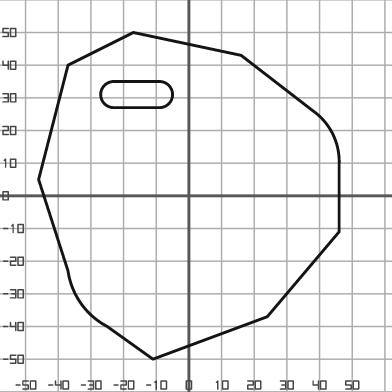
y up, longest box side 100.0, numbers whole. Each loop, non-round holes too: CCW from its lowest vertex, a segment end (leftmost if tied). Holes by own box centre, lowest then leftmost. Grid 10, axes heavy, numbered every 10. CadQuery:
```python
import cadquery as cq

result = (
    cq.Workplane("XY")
    .moveTo(-11.0, -50.0)
    .lineTo(24.0, -37.0)
    .lineTo(46.0, -11.0)
    .lineTo(46.0, 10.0)
    .threePointArc((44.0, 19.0), (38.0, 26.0))
    .lineTo(16.0, 43.0)
    .lineTo(-17.0, 50.0)
    .lineTo(-37.0, 40.0)
    .lineTo(-46.0, 5.0)
    .lineTo(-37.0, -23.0)
    .threePointArc((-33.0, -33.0), (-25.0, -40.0))
    .close()
    .moveTo(-23.0, 27.0)
    .lineTo(-9.0, 27.0)
    .threePointArc((-5.0, 31.0), (-9.0, 35.0))
    .lineTo(-23.0, 35.0)
    .threePointArc((-27.0, 31.0), (-23.0, 27.0))
    .close()
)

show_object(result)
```